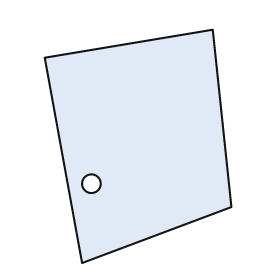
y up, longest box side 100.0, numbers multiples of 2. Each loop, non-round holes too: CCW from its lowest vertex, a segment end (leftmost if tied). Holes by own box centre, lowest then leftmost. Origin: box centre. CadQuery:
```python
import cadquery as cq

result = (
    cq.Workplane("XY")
    .moveTo(-24.0, -50.0)
    .lineTo(40.0, -26.0)
    .lineTo(32.0, 50.0)
    .lineTo(-40.0, 38.0)
    .close()
    .moveTo(-20.0, -16.0)
    .circle(4.0)
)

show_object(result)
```